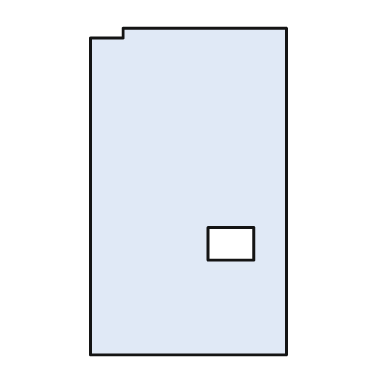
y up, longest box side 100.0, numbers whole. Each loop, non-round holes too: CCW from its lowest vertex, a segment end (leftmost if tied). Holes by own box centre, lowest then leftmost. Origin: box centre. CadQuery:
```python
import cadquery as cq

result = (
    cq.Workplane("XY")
    .moveTo(-30.0, -50.0)
    .lineTo(30.0, -50.0)
    .lineTo(30.0, 50.0)
    .lineTo(-20.0, 50.0)
    .lineTo(-20.0, 47.0)
    .lineTo(-30.0, 47.0)
    .close()
    .moveTo(6.0, -21.0)
    .lineTo(20.0, -21.0)
    .lineTo(20.0, -11.0)
    .lineTo(6.0, -11.0)
    .close()
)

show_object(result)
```